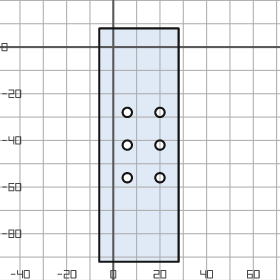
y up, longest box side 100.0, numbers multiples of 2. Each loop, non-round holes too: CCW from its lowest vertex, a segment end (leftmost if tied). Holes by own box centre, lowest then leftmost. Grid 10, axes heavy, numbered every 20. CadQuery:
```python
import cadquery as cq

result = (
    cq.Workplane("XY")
    .moveTo(-6.0, -92.0)
    .lineTo(28.0, -92.0)
    .lineTo(28.0, 8.0)
    .lineTo(-6.0, 8.0)
    .close()
    .moveTo(6.0, -56.0)
    .circle(2.0)
    .moveTo(20.0, -56.0)
    .circle(2.0)
    .moveTo(6.0, -42.0)
    .circle(2.0)
    .moveTo(20.0, -42.0)
    .circle(2.0)
    .moveTo(6.0, -28.0)
    .circle(2.0)
    .moveTo(20.0, -28.0)
    .circle(2.0)
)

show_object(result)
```